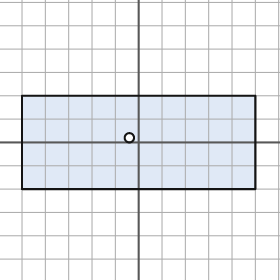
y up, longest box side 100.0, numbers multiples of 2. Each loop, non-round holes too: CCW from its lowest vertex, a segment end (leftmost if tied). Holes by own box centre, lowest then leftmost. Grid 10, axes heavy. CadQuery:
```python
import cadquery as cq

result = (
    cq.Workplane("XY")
    .moveTo(-50.0, -20.0)
    .lineTo(50.0, -20.0)
    .lineTo(50.0, 20.0)
    .lineTo(-50.0, 20.0)
    .close()
    .moveTo(-4.0, 2.0)
    .circle(2.0)
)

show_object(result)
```